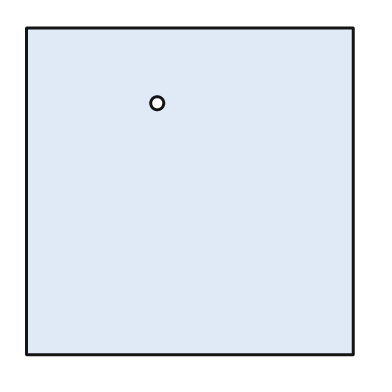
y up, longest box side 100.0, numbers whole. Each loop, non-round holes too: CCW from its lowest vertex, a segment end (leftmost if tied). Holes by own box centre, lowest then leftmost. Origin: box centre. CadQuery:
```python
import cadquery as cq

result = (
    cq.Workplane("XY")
    .moveTo(-50.0, -50.0)
    .lineTo(50.0, -50.0)
    .lineTo(50.0, 50.0)
    .lineTo(-50.0, 50.0)
    .close()
    .moveTo(-10.0, 27.0)
    .circle(2.0)
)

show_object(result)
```